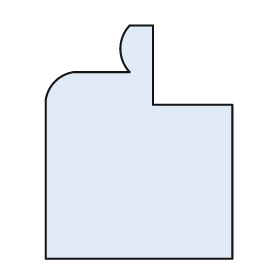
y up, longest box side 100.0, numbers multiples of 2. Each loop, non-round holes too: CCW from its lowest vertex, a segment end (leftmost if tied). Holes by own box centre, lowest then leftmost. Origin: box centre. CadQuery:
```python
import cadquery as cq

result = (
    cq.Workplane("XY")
    .moveTo(-40.0, -50.0)
    .lineTo(40.0, -50.0)
    .lineTo(40.0, 16.0)
    .lineTo(6.0, 16.0)
    .lineTo(6.0, 50.0)
    .lineTo(-4.0, 50.0)
    .threePointArc((-8.0, 40.0), (-4.0, 30.0))
    .lineTo(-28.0, 30.0)
    .threePointArc((-36.0, 26.0), (-40.0, 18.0))
    .close()
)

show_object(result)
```